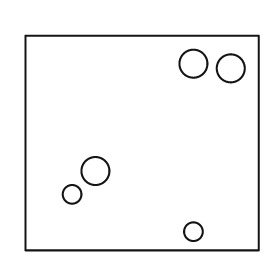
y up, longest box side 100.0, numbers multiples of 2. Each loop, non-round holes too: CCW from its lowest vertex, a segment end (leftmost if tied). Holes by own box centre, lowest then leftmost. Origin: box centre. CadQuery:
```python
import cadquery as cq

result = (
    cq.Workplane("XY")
    .moveTo(-50.0, -46.0)
    .lineTo(50.0, -46.0)
    .lineTo(50.0, 46.0)
    .lineTo(-50.0, 46.0)
    .close()
    .moveTo(22.0, -38.0)
    .circle(4.0)
    .moveTo(-30.0, -22.0)
    .circle(4.0)
    .moveTo(-20.0, -12.0)
    .circle(6.0)
    .moveTo(38.0, 32.0)
    .circle(6.0)
    .moveTo(22.0, 34.0)
    .circle(6.0)
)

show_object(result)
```